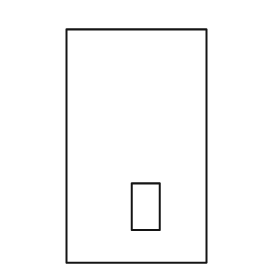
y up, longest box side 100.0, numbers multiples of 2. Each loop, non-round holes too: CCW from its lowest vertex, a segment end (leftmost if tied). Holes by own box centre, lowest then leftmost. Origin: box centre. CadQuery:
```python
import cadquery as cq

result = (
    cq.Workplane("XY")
    .moveTo(-30.0, -50.0)
    .lineTo(30.0, -50.0)
    .lineTo(30.0, 50.0)
    .lineTo(-30.0, 50.0)
    .close()
    .moveTo(-2.0, -36.0)
    .lineTo(10.0, -36.0)
    .lineTo(10.0, -16.0)
    .lineTo(-2.0, -16.0)
    .close()
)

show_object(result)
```